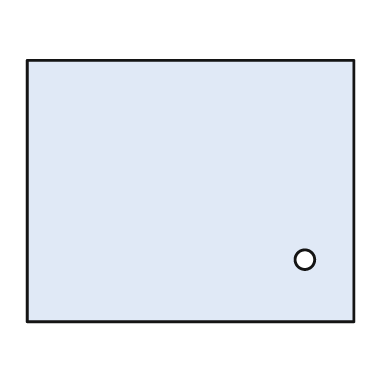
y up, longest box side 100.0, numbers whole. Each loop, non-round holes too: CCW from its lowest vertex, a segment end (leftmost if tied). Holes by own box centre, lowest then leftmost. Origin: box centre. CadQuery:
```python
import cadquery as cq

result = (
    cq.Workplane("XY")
    .moveTo(-50.0, -40.0)
    .lineTo(50.0, -40.0)
    .lineTo(50.0, 40.0)
    .lineTo(-50.0, 40.0)
    .close()
    .moveTo(35.0, -21.0)
    .circle(3.0)
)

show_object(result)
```